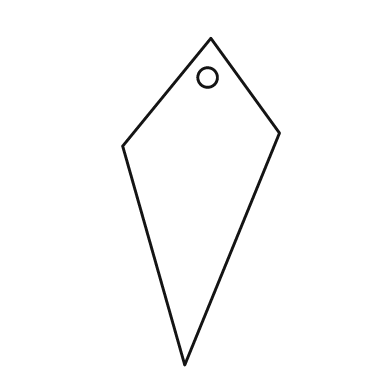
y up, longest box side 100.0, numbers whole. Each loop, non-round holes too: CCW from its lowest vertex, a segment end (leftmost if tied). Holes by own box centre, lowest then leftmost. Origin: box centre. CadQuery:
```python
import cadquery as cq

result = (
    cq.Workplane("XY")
    .moveTo(-5.0, -50.0)
    .lineTo(24.0, 21.0)
    .lineTo(3.0, 50.0)
    .lineTo(-24.0, 17.0)
    .close()
    .moveTo(2.0, 38.0)
    .circle(3.0)
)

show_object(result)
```